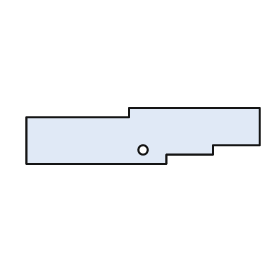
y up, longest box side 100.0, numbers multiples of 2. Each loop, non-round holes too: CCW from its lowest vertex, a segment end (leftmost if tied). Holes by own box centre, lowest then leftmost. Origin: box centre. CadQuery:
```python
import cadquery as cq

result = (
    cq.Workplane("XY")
    .moveTo(-50.0, -12.0)
    .lineTo(10.0, -12.0)
    .lineTo(10.0, -8.0)
    .lineTo(30.0, -8.0)
    .lineTo(30.0, -4.0)
    .lineTo(50.0, -4.0)
    .lineTo(50.0, 12.0)
    .lineTo(-6.0, 12.0)
    .lineTo(-6.0, 8.0)
    .lineTo(-50.0, 8.0)
    .close()
    .moveTo(0.0, -6.0)
    .circle(2.0)
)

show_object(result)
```